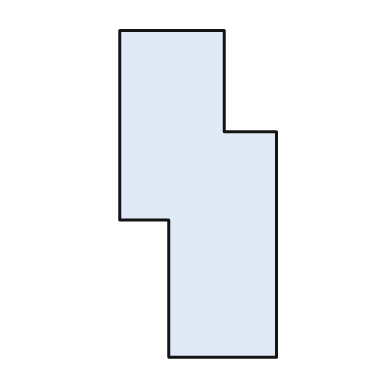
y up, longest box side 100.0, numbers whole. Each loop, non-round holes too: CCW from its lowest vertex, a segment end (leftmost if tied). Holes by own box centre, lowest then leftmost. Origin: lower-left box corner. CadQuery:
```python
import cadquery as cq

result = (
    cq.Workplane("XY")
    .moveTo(15.0, 0.0)
    .lineTo(48.0, 0.0)
    .lineTo(48.0, 69.0)
    .lineTo(32.0, 69.0)
    .lineTo(32.0, 100.0)
    .lineTo(0.0, 100.0)
    .lineTo(0.0, 42.0)
    .lineTo(15.0, 42.0)
    .close()
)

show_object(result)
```